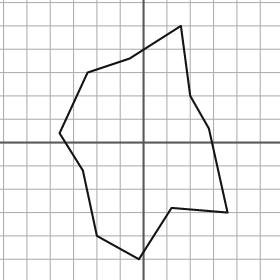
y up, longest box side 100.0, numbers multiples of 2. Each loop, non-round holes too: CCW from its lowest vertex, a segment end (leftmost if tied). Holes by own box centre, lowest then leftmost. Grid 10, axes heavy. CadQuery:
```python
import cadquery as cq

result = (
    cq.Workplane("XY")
    .moveTo(-2.0, -50.0)
    .lineTo(12.0, -28.0)
    .lineTo(36.0, -30.0)
    .lineTo(28.0, 6.0)
    .lineTo(20.0, 20.0)
    .lineTo(16.0, 50.0)
    .lineTo(-6.0, 36.0)
    .lineTo(-24.0, 30.0)
    .lineTo(-36.0, 4.0)
    .lineTo(-26.0, -12.0)
    .lineTo(-20.0, -40.0)
    .close()
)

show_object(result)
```